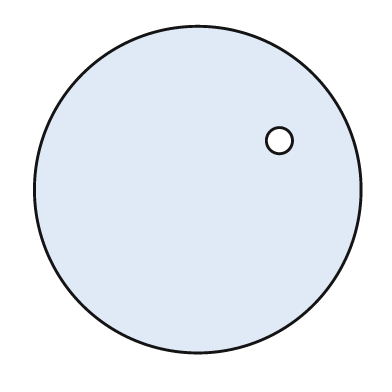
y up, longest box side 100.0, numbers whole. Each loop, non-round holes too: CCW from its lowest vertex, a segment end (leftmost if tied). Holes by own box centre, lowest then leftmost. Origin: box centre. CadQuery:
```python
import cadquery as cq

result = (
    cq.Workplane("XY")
    .moveTo(0.0, 0.0)
    .circle(50.0)
    .moveTo(25.0, 15.0)
    .circle(4.0)
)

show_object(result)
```